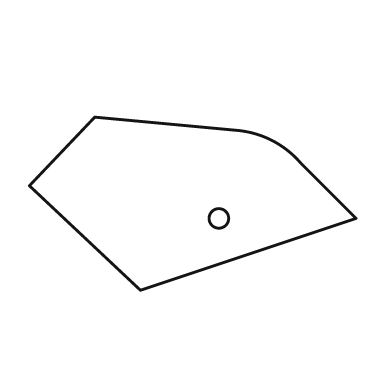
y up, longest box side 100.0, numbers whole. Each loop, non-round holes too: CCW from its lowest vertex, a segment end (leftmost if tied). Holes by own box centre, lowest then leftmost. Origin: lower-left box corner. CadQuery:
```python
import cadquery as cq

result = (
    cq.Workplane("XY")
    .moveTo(34.0, 0.0)
    .lineTo(100.0, 22.0)
    .lineTo(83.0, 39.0)
    .threePointArc((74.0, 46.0), (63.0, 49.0))
    .lineTo(20.0, 53.0)
    .lineTo(0.0, 32.0)
    .close()
    .moveTo(58.0, 22.0)
    .circle(3.0)
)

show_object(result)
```